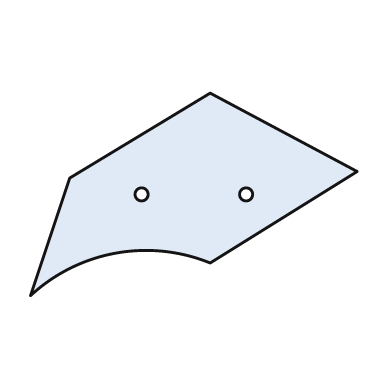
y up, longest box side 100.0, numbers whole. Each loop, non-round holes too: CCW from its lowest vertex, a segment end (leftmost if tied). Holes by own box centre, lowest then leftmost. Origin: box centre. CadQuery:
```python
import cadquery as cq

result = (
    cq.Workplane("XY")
    .moveTo(-50.0, -31.0)
    .threePointArc((-24.0, -18.0), (5.0, -21.0))
    .lineTo(50.0, 7.0)
    .lineTo(5.0, 31.0)
    .lineTo(-38.0, 5.0)
    .close()
    .moveTo(-16.0, 0.0)
    .circle(2.0)
    .moveTo(16.0, 0.0)
    .circle(2.0)
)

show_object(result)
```